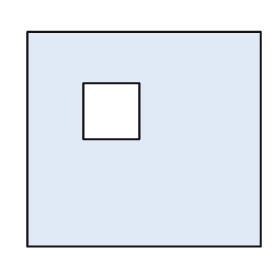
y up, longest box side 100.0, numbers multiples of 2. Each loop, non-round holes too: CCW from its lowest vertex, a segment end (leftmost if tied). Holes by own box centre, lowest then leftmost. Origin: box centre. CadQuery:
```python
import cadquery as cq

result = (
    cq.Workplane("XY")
    .moveTo(-50.0, -46.0)
    .lineTo(50.0, -46.0)
    .lineTo(50.0, 46.0)
    .lineTo(-50.0, 46.0)
    .close()
    .moveTo(-26.0, 0.0)
    .lineTo(-2.0, 0.0)
    .lineTo(-2.0, 24.0)
    .lineTo(-26.0, 24.0)
    .close()
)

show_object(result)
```